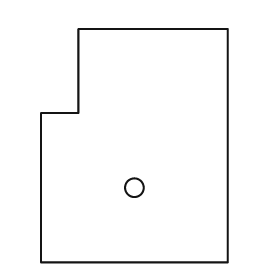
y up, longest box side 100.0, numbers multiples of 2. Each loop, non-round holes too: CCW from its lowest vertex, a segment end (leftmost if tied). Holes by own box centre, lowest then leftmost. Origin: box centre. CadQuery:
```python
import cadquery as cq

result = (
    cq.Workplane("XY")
    .moveTo(-40.0, -50.0)
    .lineTo(40.0, -50.0)
    .lineTo(40.0, 50.0)
    .lineTo(-24.0, 50.0)
    .lineTo(-24.0, 14.0)
    .lineTo(-40.0, 14.0)
    .close()
    .moveTo(0.0, -18.0)
    .circle(4.0)
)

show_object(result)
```